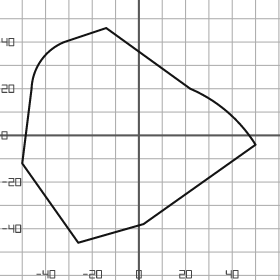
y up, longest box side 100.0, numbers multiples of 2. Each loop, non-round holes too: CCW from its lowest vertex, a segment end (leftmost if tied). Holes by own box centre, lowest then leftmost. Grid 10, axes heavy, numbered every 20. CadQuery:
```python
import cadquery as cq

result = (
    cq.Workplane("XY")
    .moveTo(-26.0, -46.0)
    .lineTo(2.0, -38.0)
    .lineTo(50.0, -4.0)
    .threePointArc((38.0, 10.0), (22.0, 20.0))
    .lineTo(-14.0, 46.0)
    .lineTo(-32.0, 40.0)
    .threePointArc((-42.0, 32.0), (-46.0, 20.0))
    .lineTo(-50.0, -12.0)
    .close()
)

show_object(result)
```